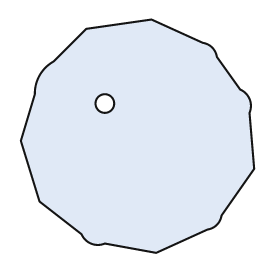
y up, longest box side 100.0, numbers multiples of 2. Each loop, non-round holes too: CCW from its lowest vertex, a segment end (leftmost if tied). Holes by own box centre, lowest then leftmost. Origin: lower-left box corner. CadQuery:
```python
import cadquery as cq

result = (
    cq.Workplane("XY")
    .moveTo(58.0, 0.0)
    .lineTo(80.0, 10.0)
    .threePointArc((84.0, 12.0), (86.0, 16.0))
    .lineTo(100.0, 36.0)
    .lineTo(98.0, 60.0)
    .threePointArc((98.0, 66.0), (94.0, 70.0))
    .lineTo(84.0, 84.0)
    .threePointArc((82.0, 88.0), (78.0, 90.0))
    .lineTo(56.0, 100.0)
    .lineTo(28.0, 96.0)
    .lineTo(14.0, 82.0)
    .threePointArc((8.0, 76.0), (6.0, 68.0))
    .lineTo(0.0, 48.0)
    .lineTo(8.0, 22.0)
    .lineTo(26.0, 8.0)
    .threePointArc((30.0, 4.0), (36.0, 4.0))
    .close()
    .moveTo(36.0, 64.0)
    .circle(4.0)
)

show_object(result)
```